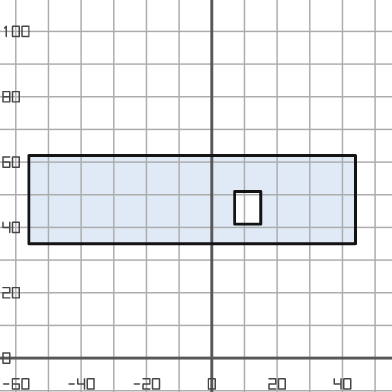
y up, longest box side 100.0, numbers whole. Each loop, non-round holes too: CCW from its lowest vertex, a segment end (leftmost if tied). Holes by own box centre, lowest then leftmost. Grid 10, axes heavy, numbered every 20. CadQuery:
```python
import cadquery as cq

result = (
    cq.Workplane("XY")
    .moveTo(-56.0, 35.0)
    .lineTo(44.0, 35.0)
    .lineTo(44.0, 62.0)
    .lineTo(-56.0, 62.0)
    .close()
    .moveTo(7.0, 41.0)
    .lineTo(15.0, 41.0)
    .lineTo(15.0, 51.0)
    .lineTo(7.0, 51.0)
    .close()
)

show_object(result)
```